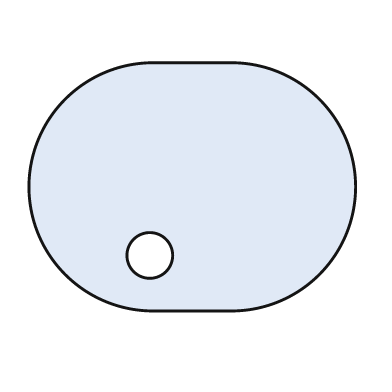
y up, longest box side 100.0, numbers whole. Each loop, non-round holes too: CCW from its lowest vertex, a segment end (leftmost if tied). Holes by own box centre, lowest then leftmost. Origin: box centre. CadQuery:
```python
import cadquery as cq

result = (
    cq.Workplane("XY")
    .moveTo(-12.0, -38.0)
    .lineTo(12.0, -38.0)
    .threePointArc((50.0, 0.0), (12.0, 38.0))
    .lineTo(-12.0, 38.0)
    .threePointArc((-50.0, 0.0), (-12.0, -38.0))
    .close()
    .moveTo(-13.0, -21.0)
    .circle(7.0)
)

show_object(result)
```